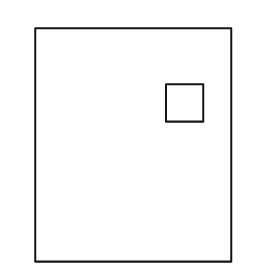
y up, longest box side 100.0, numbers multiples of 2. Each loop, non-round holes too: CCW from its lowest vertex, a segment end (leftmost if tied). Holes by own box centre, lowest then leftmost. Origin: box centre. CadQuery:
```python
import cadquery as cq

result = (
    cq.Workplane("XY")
    .moveTo(-42.0, -50.0)
    .lineTo(42.0, -50.0)
    .lineTo(42.0, 50.0)
    .lineTo(-42.0, 50.0)
    .close()
    .moveTo(14.0, 10.0)
    .lineTo(30.0, 10.0)
    .lineTo(30.0, 26.0)
    .lineTo(14.0, 26.0)
    .close()
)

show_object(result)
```